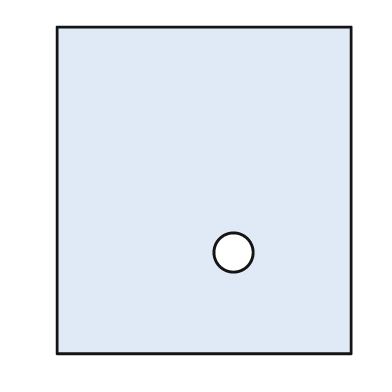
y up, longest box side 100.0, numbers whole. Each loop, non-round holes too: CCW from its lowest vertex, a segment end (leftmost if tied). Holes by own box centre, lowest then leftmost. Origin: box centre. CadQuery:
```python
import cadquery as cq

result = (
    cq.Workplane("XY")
    .moveTo(-45.0, -50.0)
    .lineTo(45.0, -50.0)
    .lineTo(45.0, 50.0)
    .lineTo(-45.0, 50.0)
    .close()
    .moveTo(9.0, -19.0)
    .circle(6.0)
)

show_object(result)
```